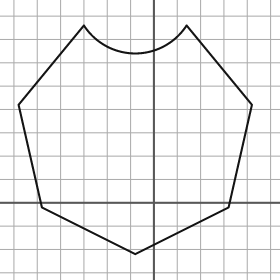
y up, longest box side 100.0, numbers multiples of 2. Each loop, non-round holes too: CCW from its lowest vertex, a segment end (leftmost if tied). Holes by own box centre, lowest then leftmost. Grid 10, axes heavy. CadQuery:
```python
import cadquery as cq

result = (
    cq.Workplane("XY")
    .moveTo(-8.0, -22.0)
    .lineTo(32.0, -2.0)
    .lineTo(42.0, 42.0)
    .lineTo(14.0, 76.0)
    .threePointArc((-8.0, 64.0), (-30.0, 76.0))
    .lineTo(-58.0, 42.0)
    .lineTo(-48.0, -2.0)
    .close()
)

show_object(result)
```